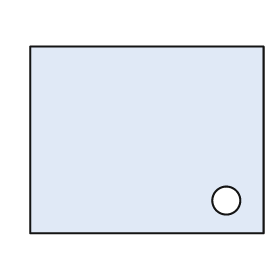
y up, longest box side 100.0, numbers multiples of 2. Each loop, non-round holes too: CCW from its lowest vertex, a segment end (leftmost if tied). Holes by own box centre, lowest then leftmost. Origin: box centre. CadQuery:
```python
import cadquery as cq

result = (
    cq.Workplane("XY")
    .moveTo(-50.0, -40.0)
    .lineTo(50.0, -40.0)
    .lineTo(50.0, 40.0)
    .lineTo(-50.0, 40.0)
    .close()
    .moveTo(34.0, -26.0)
    .circle(6.0)
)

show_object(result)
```